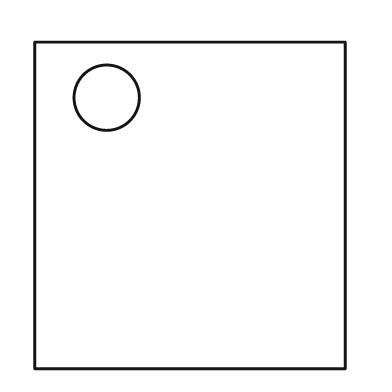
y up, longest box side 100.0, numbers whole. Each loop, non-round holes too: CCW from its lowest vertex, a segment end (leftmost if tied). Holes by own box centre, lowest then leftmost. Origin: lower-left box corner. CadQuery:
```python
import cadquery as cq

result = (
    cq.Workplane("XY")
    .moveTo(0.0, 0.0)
    .lineTo(95.0, 0.0)
    .lineTo(95.0, 100.0)
    .lineTo(0.0, 100.0)
    .close()
    .moveTo(22.0, 83.0)
    .circle(10.0)
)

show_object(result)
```